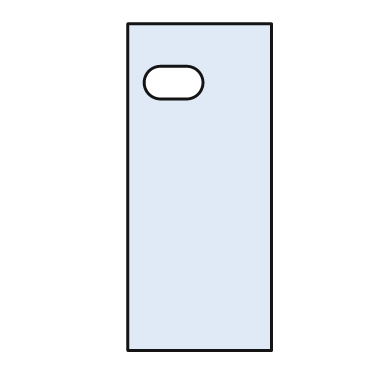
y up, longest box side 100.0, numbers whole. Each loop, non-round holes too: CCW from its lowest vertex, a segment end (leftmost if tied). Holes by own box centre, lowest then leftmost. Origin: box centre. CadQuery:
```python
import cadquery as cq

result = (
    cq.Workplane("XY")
    .moveTo(-22.0, -50.0)
    .lineTo(22.0, -50.0)
    .lineTo(22.0, 50.0)
    .lineTo(-22.0, 50.0)
    .close()
    .moveTo(-12.0, 27.0)
    .lineTo(-4.0, 27.0)
    .threePointArc((1.0, 32.0), (-4.0, 37.0))
    .lineTo(-12.0, 37.0)
    .threePointArc((-17.0, 32.0), (-12.0, 27.0))
    .close()
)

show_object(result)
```